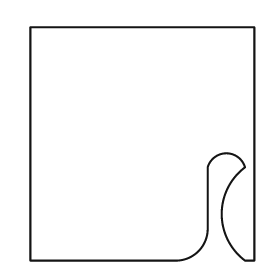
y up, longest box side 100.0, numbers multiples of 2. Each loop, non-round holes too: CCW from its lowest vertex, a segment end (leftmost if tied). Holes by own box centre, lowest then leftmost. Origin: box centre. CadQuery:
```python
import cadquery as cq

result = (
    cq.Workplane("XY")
    .moveTo(-48.0, -50.0)
    .lineTo(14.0, -50.0)
    .threePointArc((24.0, -46.0), (28.0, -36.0))
    .lineTo(28.0, -10.0)
    .threePointArc((36.0, -4.0), (44.0, -10.0))
    .threePointArc((34.0, -30.0), (44.0, -50.0))
    .lineTo(48.0, -50.0)
    .lineTo(48.0, 50.0)
    .lineTo(-48.0, 50.0)
    .close()
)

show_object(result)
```